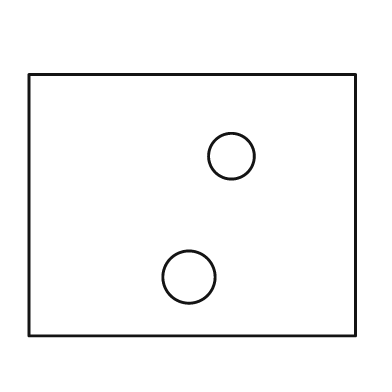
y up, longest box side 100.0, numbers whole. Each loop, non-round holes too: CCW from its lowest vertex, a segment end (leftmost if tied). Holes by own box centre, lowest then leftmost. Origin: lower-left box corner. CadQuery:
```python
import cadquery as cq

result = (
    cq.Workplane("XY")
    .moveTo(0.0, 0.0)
    .lineTo(100.0, 0.0)
    .lineTo(100.0, 80.0)
    .lineTo(0.0, 80.0)
    .close()
    .moveTo(49.0, 18.0)
    .circle(8.0)
    .moveTo(62.0, 55.0)
    .circle(7.0)
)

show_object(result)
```